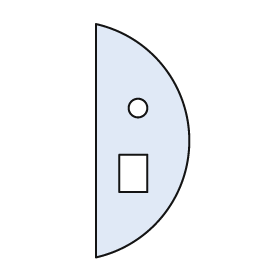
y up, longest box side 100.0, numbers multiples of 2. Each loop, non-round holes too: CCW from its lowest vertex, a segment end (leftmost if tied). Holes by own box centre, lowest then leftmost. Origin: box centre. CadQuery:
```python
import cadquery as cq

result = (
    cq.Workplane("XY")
    .moveTo(-20.0, -50.0)
    .threePointArc((20.0, 0.0), (-20.0, 50.0))
    .close()
    .moveTo(-10.0, -22.0)
    .lineTo(2.0, -22.0)
    .lineTo(2.0, -6.0)
    .lineTo(-10.0, -6.0)
    .close()
    .moveTo(-2.0, 14.0)
    .circle(4.0)
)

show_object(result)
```